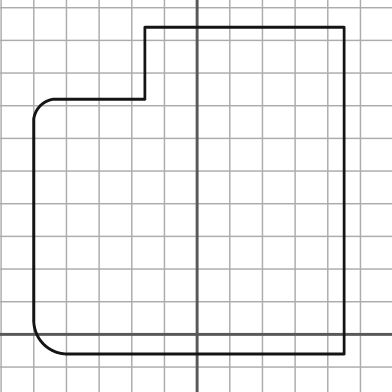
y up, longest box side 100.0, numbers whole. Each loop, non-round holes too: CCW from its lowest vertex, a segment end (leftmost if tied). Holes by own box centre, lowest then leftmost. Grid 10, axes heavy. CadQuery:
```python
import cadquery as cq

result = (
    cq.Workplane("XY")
    .moveTo(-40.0, -6.0)
    .lineTo(45.0, -6.0)
    .lineTo(45.0, 94.0)
    .lineTo(-16.0, 94.0)
    .lineTo(-16.0, 72.0)
    .lineTo(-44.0, 72.0)
    .threePointArc((-48.0, 70.0), (-50.0, 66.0))
    .lineTo(-50.0, 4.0)
    .threePointArc((-47.0, -3.0), (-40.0, -6.0))
    .close()
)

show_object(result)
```